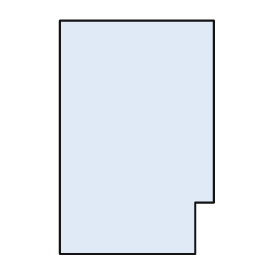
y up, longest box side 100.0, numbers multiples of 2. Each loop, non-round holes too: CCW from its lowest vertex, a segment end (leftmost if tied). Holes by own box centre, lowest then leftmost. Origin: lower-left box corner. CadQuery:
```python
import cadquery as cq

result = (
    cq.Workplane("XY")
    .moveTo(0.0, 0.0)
    .lineTo(58.0, 0.0)
    .lineTo(58.0, 22.0)
    .lineTo(66.0, 22.0)
    .lineTo(66.0, 100.0)
    .lineTo(0.0, 100.0)
    .close()
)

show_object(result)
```